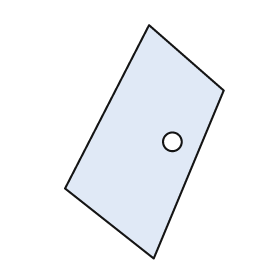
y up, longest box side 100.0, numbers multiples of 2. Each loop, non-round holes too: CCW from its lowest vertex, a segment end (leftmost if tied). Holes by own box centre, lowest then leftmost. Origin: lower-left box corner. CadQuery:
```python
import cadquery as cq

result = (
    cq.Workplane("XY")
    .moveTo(38.0, 0.0)
    .lineTo(68.0, 72.0)
    .lineTo(36.0, 100.0)
    .lineTo(0.0, 30.0)
    .close()
    .moveTo(46.0, 50.0)
    .circle(4.0)
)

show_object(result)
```